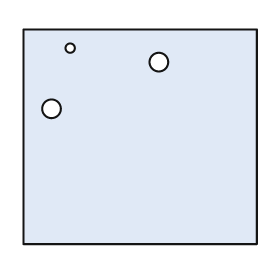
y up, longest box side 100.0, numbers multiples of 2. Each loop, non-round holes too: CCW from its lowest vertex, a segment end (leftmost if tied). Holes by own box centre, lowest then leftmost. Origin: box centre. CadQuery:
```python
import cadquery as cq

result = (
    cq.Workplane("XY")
    .moveTo(-50.0, -46.0)
    .lineTo(50.0, -46.0)
    .lineTo(50.0, 46.0)
    .lineTo(-50.0, 46.0)
    .close()
    .moveTo(-38.0, 12.0)
    .circle(4.0)
    .moveTo(8.0, 32.0)
    .circle(4.0)
    .moveTo(-30.0, 38.0)
    .circle(2.0)
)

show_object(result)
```